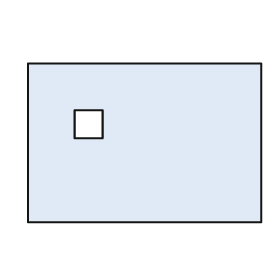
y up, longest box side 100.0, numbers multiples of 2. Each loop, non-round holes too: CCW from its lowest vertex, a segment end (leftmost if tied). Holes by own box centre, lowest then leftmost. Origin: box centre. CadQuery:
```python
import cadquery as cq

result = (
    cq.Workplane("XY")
    .moveTo(-50.0, -34.0)
    .lineTo(50.0, -34.0)
    .lineTo(50.0, 34.0)
    .lineTo(-50.0, 34.0)
    .close()
    .moveTo(-30.0, 2.0)
    .lineTo(-18.0, 2.0)
    .lineTo(-18.0, 14.0)
    .lineTo(-30.0, 14.0)
    .close()
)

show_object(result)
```